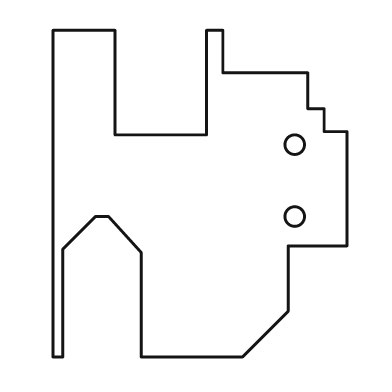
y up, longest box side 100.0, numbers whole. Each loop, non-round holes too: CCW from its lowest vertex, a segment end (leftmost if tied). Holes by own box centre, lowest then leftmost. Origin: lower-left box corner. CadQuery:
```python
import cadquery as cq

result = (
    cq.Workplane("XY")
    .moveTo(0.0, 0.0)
    .lineTo(3.0, 0.0)
    .lineTo(3.0, 33.0)
    .lineTo(13.0, 43.0)
    .lineTo(17.0, 43.0)
    .lineTo(27.0, 32.0)
    .lineTo(27.0, 0.0)
    .lineTo(58.0, 0.0)
    .lineTo(72.0, 14.0)
    .lineTo(72.0, 34.0)
    .lineTo(90.0, 34.0)
    .lineTo(90.0, 69.0)
    .lineTo(83.0, 69.0)
    .lineTo(83.0, 76.0)
    .lineTo(78.0, 76.0)
    .lineTo(78.0, 87.0)
    .lineTo(52.0, 87.0)
    .lineTo(52.0, 100.0)
    .lineTo(47.0, 100.0)
    .lineTo(47.0, 68.0)
    .lineTo(19.0, 68.0)
    .lineTo(19.0, 100.0)
    .lineTo(0.0, 100.0)
    .close()
    .moveTo(74.0, 43.0)
    .circle(3.0)
    .moveTo(74.0, 65.0)
    .circle(3.0)
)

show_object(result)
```